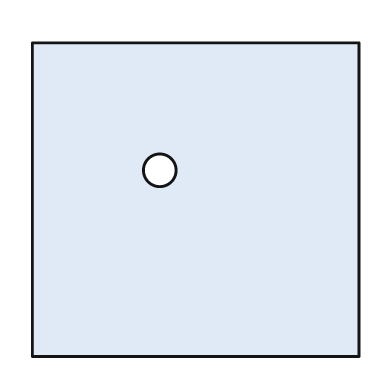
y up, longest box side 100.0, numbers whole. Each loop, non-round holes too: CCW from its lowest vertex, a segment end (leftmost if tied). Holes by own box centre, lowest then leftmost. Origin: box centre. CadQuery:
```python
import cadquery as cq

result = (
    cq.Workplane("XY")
    .moveTo(-50.0, -48.0)
    .lineTo(50.0, -48.0)
    .lineTo(50.0, 48.0)
    .lineTo(-50.0, 48.0)
    .close()
    .moveTo(-11.0, 9.0)
    .circle(5.0)
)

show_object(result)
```